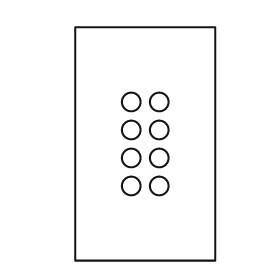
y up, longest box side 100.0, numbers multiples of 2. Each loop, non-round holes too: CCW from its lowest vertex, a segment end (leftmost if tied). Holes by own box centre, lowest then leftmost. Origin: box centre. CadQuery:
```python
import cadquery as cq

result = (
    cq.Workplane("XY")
    .moveTo(-30.0, -50.0)
    .lineTo(30.0, -50.0)
    .lineTo(30.0, 50.0)
    .lineTo(-30.0, 50.0)
    .close()
    .moveTo(-6.0, -18.0)
    .circle(4.0)
    .moveTo(6.0, -18.0)
    .circle(4.0)
    .moveTo(-6.0, -6.0)
    .circle(4.0)
    .moveTo(6.0, -6.0)
    .circle(4.0)
    .moveTo(-6.0, 6.0)
    .circle(4.0)
    .moveTo(6.0, 6.0)
    .circle(4.0)
    .moveTo(-6.0, 18.0)
    .circle(4.0)
    .moveTo(6.0, 18.0)
    .circle(4.0)
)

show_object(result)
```